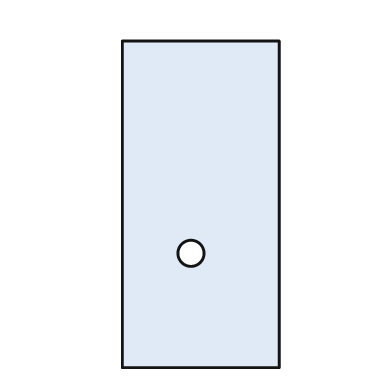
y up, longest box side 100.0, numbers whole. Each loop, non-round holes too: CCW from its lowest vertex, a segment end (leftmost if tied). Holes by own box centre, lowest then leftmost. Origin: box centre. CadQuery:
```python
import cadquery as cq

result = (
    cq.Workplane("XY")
    .moveTo(-24.0, -50.0)
    .lineTo(24.0, -50.0)
    .lineTo(24.0, 50.0)
    .lineTo(-24.0, 50.0)
    .close()
    .moveTo(-3.0, -15.0)
    .circle(4.0)
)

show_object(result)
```